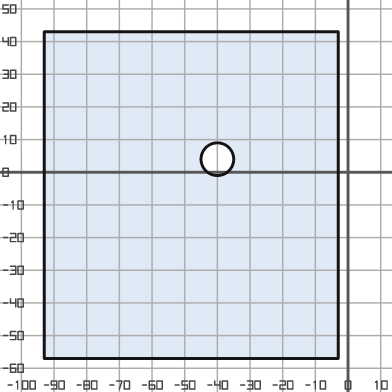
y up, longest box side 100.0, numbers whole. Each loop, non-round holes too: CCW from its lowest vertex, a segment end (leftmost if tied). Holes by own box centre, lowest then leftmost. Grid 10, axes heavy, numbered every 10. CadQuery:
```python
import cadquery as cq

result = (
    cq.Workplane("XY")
    .moveTo(-93.0, -57.0)
    .lineTo(-3.0, -57.0)
    .lineTo(-3.0, 43.0)
    .lineTo(-93.0, 43.0)
    .close()
    .moveTo(-40.0, 4.0)
    .circle(5.0)
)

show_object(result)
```